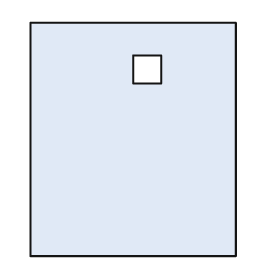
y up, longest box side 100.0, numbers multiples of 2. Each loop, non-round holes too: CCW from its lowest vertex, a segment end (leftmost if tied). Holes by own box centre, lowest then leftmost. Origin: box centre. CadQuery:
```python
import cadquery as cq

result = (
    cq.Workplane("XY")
    .moveTo(-44.0, -50.0)
    .lineTo(44.0, -50.0)
    .lineTo(44.0, 50.0)
    .lineTo(-44.0, 50.0)
    .close()
    .moveTo(0.0, 24.0)
    .lineTo(12.0, 24.0)
    .lineTo(12.0, 36.0)
    .lineTo(0.0, 36.0)
    .close()
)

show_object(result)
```